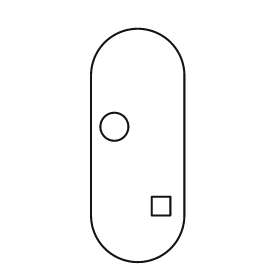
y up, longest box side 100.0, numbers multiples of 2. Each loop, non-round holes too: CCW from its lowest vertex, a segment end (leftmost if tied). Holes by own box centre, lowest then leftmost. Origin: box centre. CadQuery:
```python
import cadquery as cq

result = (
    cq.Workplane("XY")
    .moveTo(-20.0, -30.0)
    .threePointArc((0.0, -50.0), (20.0, -30.0))
    .lineTo(20.0, 30.0)
    .threePointArc((0.0, 50.0), (-20.0, 30.0))
    .close()
    .moveTo(6.0, -30.0)
    .lineTo(14.0, -30.0)
    .lineTo(14.0, -22.0)
    .lineTo(6.0, -22.0)
    .close()
    .moveTo(-10.0, 8.0)
    .circle(6.0)
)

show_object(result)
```